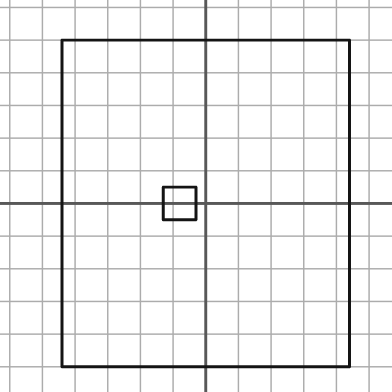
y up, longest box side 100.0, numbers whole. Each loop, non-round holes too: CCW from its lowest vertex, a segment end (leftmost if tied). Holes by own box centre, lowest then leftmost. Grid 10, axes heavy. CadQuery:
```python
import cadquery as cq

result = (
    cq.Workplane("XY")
    .moveTo(-44.0, -50.0)
    .lineTo(44.0, -50.0)
    .lineTo(44.0, 50.0)
    .lineTo(-44.0, 50.0)
    .close()
    .moveTo(-13.0, -5.0)
    .lineTo(-3.0, -5.0)
    .lineTo(-3.0, 5.0)
    .lineTo(-13.0, 5.0)
    .close()
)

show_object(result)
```